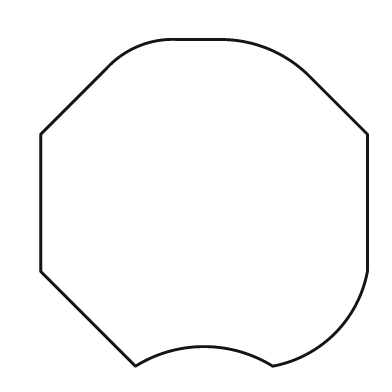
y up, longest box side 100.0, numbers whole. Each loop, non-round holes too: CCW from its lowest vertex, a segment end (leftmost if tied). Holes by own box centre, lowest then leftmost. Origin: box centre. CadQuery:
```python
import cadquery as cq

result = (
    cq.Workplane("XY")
    .moveTo(-21.0, -50.0)
    .threePointArc((0.0, -44.0), (21.0, -50.0))
    .threePointArc((40.0, -40.0), (50.0, -21.0))
    .lineTo(50.0, 21.0)
    .lineTo(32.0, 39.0)
    .threePointArc((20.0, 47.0), (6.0, 50.0))
    .lineTo(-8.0, 50.0)
    .threePointArc((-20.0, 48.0), (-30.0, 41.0))
    .lineTo(-50.0, 21.0)
    .lineTo(-50.0, -21.0)
    .close()
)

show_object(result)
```